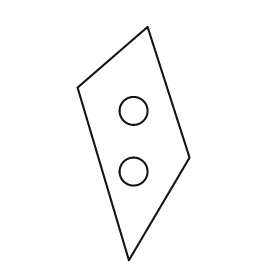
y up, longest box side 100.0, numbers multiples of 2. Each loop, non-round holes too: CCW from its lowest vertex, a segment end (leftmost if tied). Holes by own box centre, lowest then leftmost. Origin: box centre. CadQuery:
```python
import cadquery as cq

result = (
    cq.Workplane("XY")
    .moveTo(-2.0, -50.0)
    .lineTo(24.0, -6.0)
    .lineTo(6.0, 50.0)
    .lineTo(-24.0, 24.0)
    .close()
    .moveTo(0.0, -12.0)
    .circle(6.0)
    .moveTo(0.0, 14.0)
    .circle(6.0)
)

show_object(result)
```